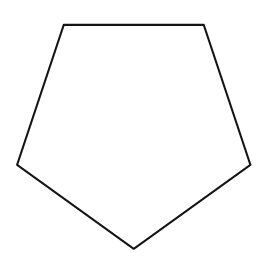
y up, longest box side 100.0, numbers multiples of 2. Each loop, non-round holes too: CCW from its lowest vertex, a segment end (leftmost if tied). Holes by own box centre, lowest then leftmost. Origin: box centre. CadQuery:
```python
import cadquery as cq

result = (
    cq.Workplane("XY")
    .moveTo(0.0, -48.0)
    .lineTo(50.0, -12.0)
    .lineTo(30.0, 48.0)
    .lineTo(-30.0, 48.0)
    .lineTo(-50.0, -12.0)
    .close()
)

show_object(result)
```